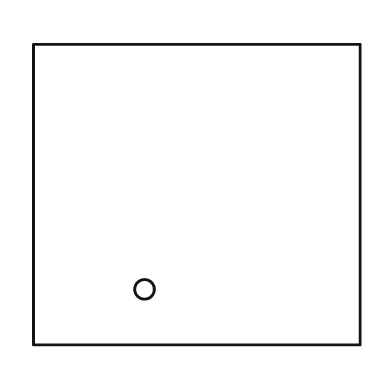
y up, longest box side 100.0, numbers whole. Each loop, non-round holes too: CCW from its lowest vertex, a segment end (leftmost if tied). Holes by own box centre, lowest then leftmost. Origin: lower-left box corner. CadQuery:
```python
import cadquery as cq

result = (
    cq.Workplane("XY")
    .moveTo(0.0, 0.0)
    .lineTo(100.0, 0.0)
    .lineTo(100.0, 92.0)
    .lineTo(0.0, 92.0)
    .close()
    .moveTo(34.0, 17.0)
    .circle(3.0)
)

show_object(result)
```